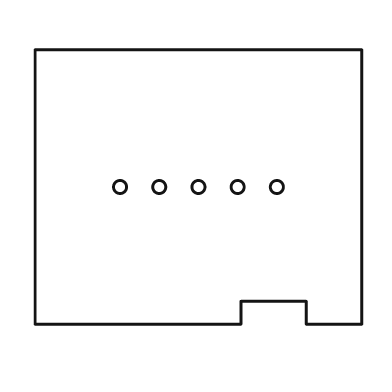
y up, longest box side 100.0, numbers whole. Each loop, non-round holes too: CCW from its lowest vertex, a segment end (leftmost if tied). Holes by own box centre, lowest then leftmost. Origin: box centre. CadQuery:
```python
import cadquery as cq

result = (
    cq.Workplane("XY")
    .moveTo(-50.0, -42.0)
    .lineTo(13.0, -42.0)
    .lineTo(13.0, -35.0)
    .lineTo(33.0, -35.0)
    .lineTo(33.0, -42.0)
    .lineTo(50.0, -42.0)
    .lineTo(50.0, 42.0)
    .lineTo(-50.0, 42.0)
    .close()
    .moveTo(-24.0, 0.0)
    .circle(2.0)
    .moveTo(-12.0, 0.0)
    .circle(2.0)
    .moveTo(0.0, 0.0)
    .circle(2.0)
    .moveTo(12.0, 0.0)
    .circle(2.0)
    .moveTo(24.0, 0.0)
    .circle(2.0)
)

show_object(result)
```